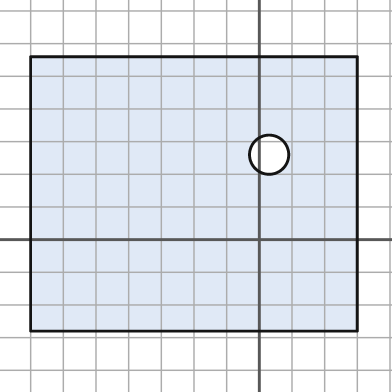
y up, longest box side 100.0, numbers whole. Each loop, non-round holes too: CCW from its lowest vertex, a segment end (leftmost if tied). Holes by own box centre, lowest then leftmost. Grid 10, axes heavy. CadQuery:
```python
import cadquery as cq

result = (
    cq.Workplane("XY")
    .moveTo(-70.0, -28.0)
    .lineTo(30.0, -28.0)
    .lineTo(30.0, 56.0)
    .lineTo(-70.0, 56.0)
    .close()
    .moveTo(3.0, 26.0)
    .circle(6.0)
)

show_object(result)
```